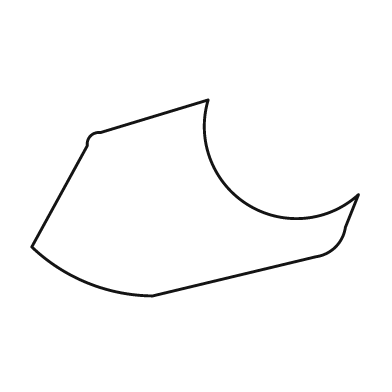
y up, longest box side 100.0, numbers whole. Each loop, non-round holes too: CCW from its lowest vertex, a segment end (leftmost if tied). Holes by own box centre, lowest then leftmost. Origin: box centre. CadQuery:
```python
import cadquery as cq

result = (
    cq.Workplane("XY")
    .moveTo(-13.0, -30.0)
    .lineTo(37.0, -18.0)
    .threePointArc((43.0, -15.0), (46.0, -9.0))
    .lineTo(50.0, 1.0)
    .threePointArc((16.0, -2.0), (4.0, 30.0))
    .lineTo(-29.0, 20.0)
    .threePointArc((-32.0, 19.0), (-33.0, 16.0))
    .lineTo(-50.0, -15.0)
    .threePointArc((-33.0, -26.0), (-13.0, -30.0))
    .close()
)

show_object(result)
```